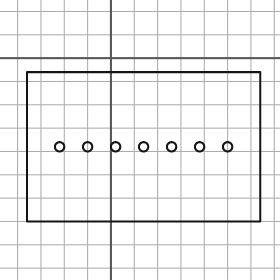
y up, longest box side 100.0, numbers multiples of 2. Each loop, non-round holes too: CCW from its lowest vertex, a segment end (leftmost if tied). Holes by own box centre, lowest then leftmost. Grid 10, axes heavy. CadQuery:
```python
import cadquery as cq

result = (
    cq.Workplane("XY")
    .moveTo(-36.0, -70.0)
    .lineTo(64.0, -70.0)
    .lineTo(64.0, -6.0)
    .lineTo(-36.0, -6.0)
    .close()
    .moveTo(-22.0, -38.0)
    .circle(2.0)
    .moveTo(-10.0, -38.0)
    .circle(2.0)
    .moveTo(2.0, -38.0)
    .circle(2.0)
    .moveTo(14.0, -38.0)
    .circle(2.0)
    .moveTo(26.0, -38.0)
    .circle(2.0)
    .moveTo(38.0, -38.0)
    .circle(2.0)
    .moveTo(50.0, -38.0)
    .circle(2.0)
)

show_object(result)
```